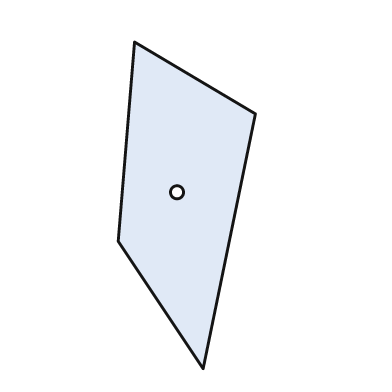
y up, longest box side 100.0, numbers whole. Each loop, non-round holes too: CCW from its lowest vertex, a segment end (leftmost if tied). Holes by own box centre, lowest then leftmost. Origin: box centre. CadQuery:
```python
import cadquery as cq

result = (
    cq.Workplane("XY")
    .moveTo(5.0, -50.0)
    .lineTo(21.0, 28.0)
    .lineTo(-16.0, 50.0)
    .lineTo(-21.0, -11.0)
    .close()
    .moveTo(-3.0, 4.0)
    .circle(2.0)
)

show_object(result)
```